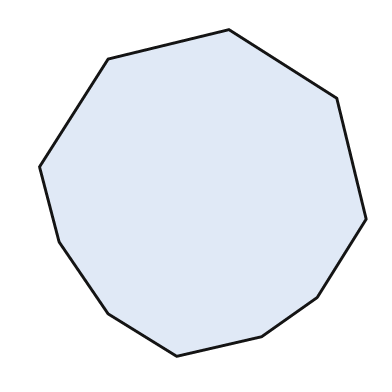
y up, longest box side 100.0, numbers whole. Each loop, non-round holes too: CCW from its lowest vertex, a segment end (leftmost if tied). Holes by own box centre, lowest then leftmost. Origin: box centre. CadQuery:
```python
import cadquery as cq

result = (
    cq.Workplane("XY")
    .moveTo(-8.0, -50.0)
    .lineTo(18.0, -44.0)
    .lineTo(35.0, -32.0)
    .lineTo(50.0, -8.0)
    .lineTo(41.0, 29.0)
    .lineTo(8.0, 50.0)
    .lineTo(-29.0, 41.0)
    .lineTo(-50.0, 8.0)
    .lineTo(-44.0, -15.0)
    .lineTo(-29.0, -37.0)
    .close()
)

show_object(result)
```